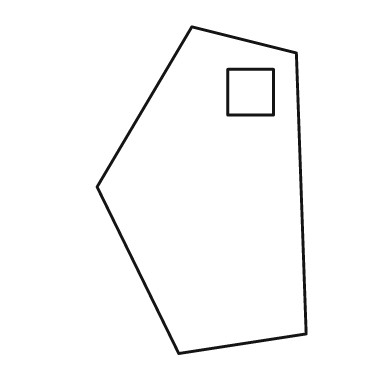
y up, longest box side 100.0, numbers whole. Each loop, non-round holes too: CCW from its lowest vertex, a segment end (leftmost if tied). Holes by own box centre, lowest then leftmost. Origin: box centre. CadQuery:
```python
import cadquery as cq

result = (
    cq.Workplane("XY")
    .moveTo(-7.0, -50.0)
    .lineTo(32.0, -44.0)
    .lineTo(29.0, 42.0)
    .lineTo(-3.0, 50.0)
    .lineTo(-32.0, 1.0)
    .close()
    .moveTo(8.0, 23.0)
    .lineTo(22.0, 23.0)
    .lineTo(22.0, 37.0)
    .lineTo(8.0, 37.0)
    .close()
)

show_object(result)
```